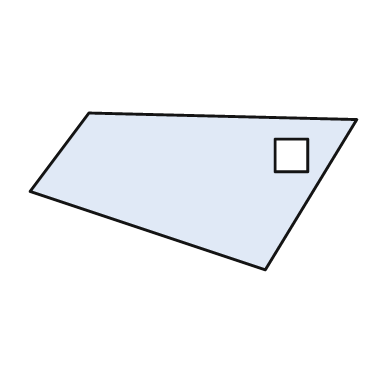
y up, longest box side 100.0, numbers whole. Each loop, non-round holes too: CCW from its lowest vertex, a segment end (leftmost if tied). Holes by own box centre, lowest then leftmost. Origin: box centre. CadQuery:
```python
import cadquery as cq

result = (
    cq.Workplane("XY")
    .moveTo(22.0, -24.0)
    .lineTo(50.0, 22.0)
    .lineTo(-32.0, 24.0)
    .lineTo(-50.0, 0.0)
    .close()
    .moveTo(25.0, 6.0)
    .lineTo(35.0, 6.0)
    .lineTo(35.0, 16.0)
    .lineTo(25.0, 16.0)
    .close()
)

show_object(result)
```